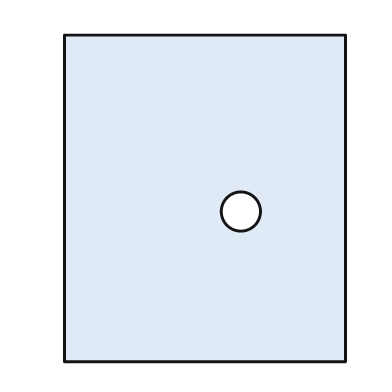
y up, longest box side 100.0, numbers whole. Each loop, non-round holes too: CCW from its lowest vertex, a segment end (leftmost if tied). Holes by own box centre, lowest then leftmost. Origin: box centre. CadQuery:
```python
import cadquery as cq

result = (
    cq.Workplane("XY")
    .moveTo(-43.0, -50.0)
    .lineTo(43.0, -50.0)
    .lineTo(43.0, 50.0)
    .lineTo(-43.0, 50.0)
    .close()
    .moveTo(11.0, -4.0)
    .circle(6.0)
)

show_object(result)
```